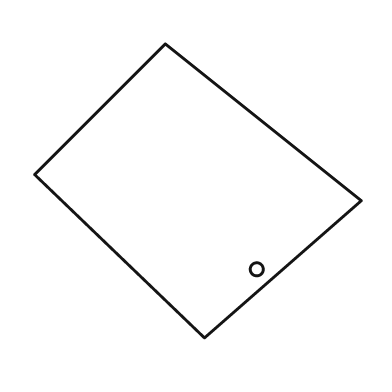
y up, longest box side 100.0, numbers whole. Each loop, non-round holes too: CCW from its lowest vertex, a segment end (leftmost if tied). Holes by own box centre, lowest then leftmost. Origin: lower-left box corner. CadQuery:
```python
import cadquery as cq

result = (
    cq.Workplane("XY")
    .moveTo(52.0, 0.0)
    .lineTo(100.0, 42.0)
    .lineTo(40.0, 90.0)
    .lineTo(0.0, 50.0)
    .close()
    .moveTo(68.0, 21.0)
    .circle(2.0)
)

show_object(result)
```